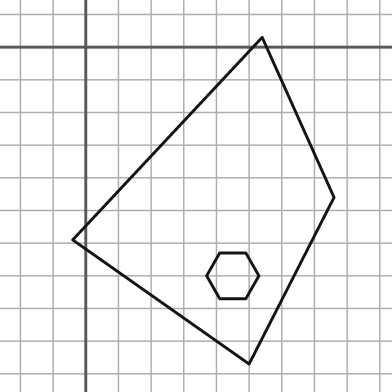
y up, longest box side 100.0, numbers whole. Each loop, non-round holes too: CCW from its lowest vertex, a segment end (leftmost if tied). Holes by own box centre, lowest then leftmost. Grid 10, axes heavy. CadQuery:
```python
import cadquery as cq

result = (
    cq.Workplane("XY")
    .moveTo(50.0, -97.0)
    .lineTo(76.0, -46.0)
    .lineTo(54.0, 3.0)
    .lineTo(-4.0, -59.0)
    .close()
    .moveTo(41.0, -77.0)
    .lineTo(49.0, -77.0)
    .lineTo(53.0, -70.0)
    .lineTo(49.0, -63.0)
    .lineTo(41.0, -63.0)
    .lineTo(37.0, -70.0)
    .close()
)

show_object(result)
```